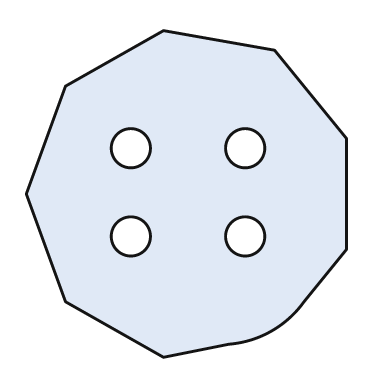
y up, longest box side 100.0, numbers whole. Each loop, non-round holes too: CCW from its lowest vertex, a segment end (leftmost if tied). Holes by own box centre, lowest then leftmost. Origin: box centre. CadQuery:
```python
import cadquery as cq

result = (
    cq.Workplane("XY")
    .moveTo(-7.0, -50.0)
    .lineTo(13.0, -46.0)
    .threePointArc((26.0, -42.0), (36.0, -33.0))
    .lineTo(49.0, -17.0)
    .lineTo(49.0, 17.0)
    .lineTo(27.0, 44.0)
    .lineTo(-7.0, 50.0)
    .lineTo(-37.0, 33.0)
    .lineTo(-49.0, 0.0)
    .lineTo(-37.0, -33.0)
    .close()
    .moveTo(-17.0, -13.0)
    .circle(6.0)
    .moveTo(18.0, -13.0)
    .circle(6.0)
    .moveTo(-17.0, 14.0)
    .circle(6.0)
    .moveTo(18.0, 14.0)
    .circle(6.0)
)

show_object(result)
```